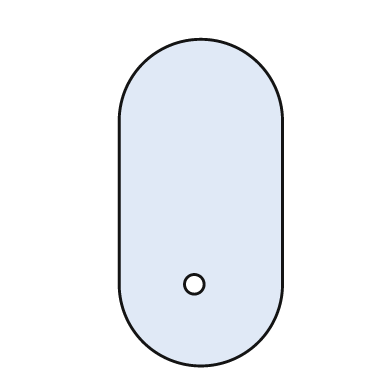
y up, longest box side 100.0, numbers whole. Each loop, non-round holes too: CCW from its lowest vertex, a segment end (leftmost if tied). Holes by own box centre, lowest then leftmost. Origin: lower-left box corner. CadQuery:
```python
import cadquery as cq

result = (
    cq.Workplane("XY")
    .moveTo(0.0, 25.0)
    .threePointArc((25.0, 0.0), (50.0, 25.0))
    .lineTo(50.0, 75.0)
    .threePointArc((25.0, 100.0), (0.0, 75.0))
    .close()
    .moveTo(23.0, 25.0)
    .circle(3.0)
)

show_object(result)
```